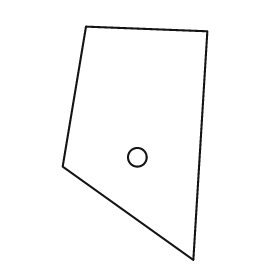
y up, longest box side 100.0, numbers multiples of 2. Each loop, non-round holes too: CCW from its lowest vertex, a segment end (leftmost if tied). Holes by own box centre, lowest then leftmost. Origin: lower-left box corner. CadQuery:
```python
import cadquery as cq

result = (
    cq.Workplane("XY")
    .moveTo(56.0, 0.0)
    .lineTo(62.0, 98.0)
    .lineTo(10.0, 100.0)
    .lineTo(0.0, 40.0)
    .close()
    .moveTo(32.0, 44.0)
    .circle(4.0)
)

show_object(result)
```